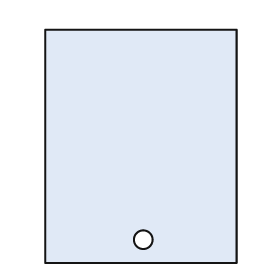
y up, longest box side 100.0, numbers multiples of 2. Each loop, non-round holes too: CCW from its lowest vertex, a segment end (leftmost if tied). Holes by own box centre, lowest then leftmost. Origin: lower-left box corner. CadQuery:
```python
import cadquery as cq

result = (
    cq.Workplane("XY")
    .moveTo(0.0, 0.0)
    .lineTo(82.0, 0.0)
    .lineTo(82.0, 100.0)
    .lineTo(0.0, 100.0)
    .close()
    .moveTo(42.0, 10.0)
    .circle(4.0)
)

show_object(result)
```